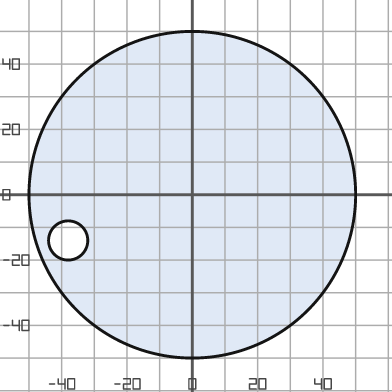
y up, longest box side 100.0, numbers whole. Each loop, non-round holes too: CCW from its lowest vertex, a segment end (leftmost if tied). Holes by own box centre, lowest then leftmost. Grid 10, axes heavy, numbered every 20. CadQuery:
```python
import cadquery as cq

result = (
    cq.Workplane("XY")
    .moveTo(0.0, 0.0)
    .circle(50.0)
    .moveTo(-38.0, -14.0)
    .circle(6.0)
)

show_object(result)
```